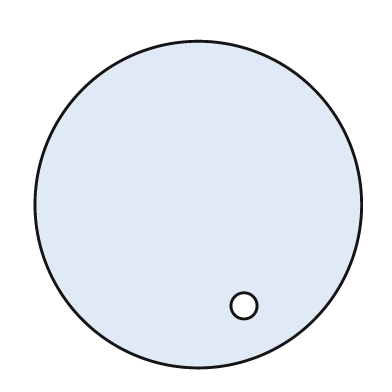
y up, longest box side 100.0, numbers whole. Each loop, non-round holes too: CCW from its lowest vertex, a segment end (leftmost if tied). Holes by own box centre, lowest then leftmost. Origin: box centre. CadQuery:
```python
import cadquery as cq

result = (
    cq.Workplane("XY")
    .moveTo(0.0, 0.0)
    .circle(50.0)
    .moveTo(14.0, -31.0)
    .circle(4.0)
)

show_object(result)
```